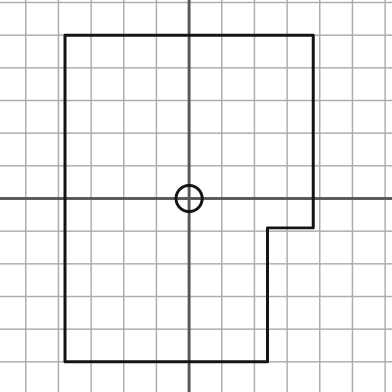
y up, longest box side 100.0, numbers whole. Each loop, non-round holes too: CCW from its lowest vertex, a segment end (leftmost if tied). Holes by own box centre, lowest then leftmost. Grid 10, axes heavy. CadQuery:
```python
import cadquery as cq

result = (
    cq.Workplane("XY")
    .moveTo(-38.0, -50.0)
    .lineTo(24.0, -50.0)
    .lineTo(24.0, -9.0)
    .lineTo(38.0, -9.0)
    .lineTo(38.0, 50.0)
    .lineTo(-38.0, 50.0)
    .close()
    .moveTo(0.0, 0.0)
    .circle(4.0)
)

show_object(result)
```